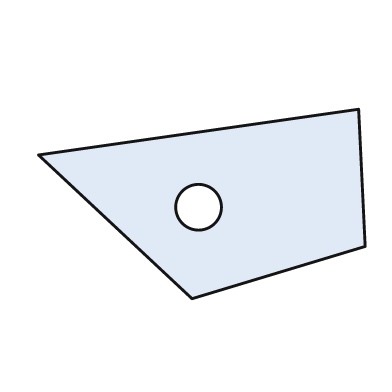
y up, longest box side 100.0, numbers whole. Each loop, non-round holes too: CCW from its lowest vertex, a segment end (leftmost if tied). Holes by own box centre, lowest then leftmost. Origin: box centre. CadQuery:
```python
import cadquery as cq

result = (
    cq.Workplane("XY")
    .moveTo(-3.0, -29.0)
    .lineTo(50.0, -13.0)
    .lineTo(48.0, 29.0)
    .lineTo(-50.0, 15.0)
    .close()
    .moveTo(-1.0, -1.0)
    .circle(7.0)
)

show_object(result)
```